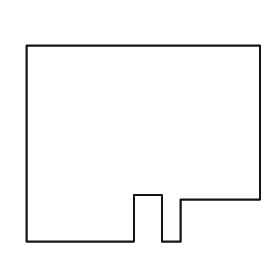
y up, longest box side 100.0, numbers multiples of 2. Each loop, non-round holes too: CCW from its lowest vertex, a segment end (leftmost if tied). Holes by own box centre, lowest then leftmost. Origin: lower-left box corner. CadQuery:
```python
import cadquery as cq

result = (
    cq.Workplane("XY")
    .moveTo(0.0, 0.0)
    .lineTo(46.0, 0.0)
    .lineTo(46.0, 20.0)
    .lineTo(58.0, 20.0)
    .lineTo(58.0, 0.0)
    .lineTo(66.0, 0.0)
    .lineTo(66.0, 18.0)
    .lineTo(100.0, 18.0)
    .lineTo(100.0, 84.0)
    .lineTo(0.0, 84.0)
    .close()
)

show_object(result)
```